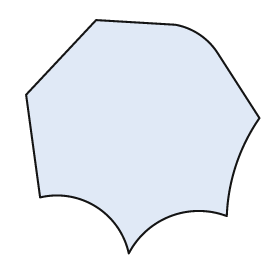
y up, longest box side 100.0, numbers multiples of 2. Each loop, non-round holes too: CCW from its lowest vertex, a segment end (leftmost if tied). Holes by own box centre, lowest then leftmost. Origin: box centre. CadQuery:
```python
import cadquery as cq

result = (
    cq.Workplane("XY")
    .moveTo(-6.0, -50.0)
    .threePointArc((12.0, -34.0), (36.0, -34.0))
    .threePointArc((40.0, -12.0), (50.0, 8.0))
    .lineTo(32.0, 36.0)
    .threePointArc((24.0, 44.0), (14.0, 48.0))
    .lineTo(-20.0, 50.0)
    .lineTo(-50.0, 18.0)
    .lineTo(-44.0, -26.0)
    .threePointArc((-20.0, -30.0), (-6.0, -50.0))
    .close()
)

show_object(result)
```